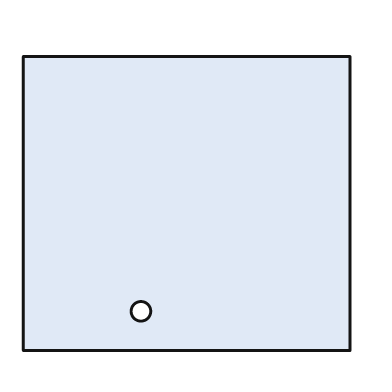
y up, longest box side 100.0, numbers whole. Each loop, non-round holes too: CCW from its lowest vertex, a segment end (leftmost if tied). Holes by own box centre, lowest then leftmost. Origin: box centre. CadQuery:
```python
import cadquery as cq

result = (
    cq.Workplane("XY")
    .moveTo(-50.0, -45.0)
    .lineTo(50.0, -45.0)
    .lineTo(50.0, 45.0)
    .lineTo(-50.0, 45.0)
    .close()
    .moveTo(-14.0, -33.0)
    .circle(3.0)
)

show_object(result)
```